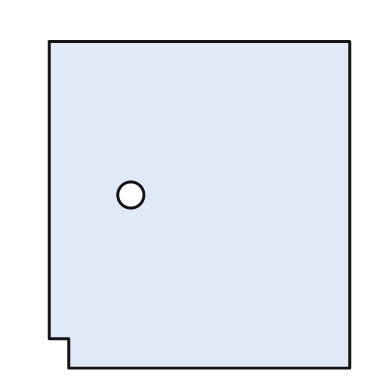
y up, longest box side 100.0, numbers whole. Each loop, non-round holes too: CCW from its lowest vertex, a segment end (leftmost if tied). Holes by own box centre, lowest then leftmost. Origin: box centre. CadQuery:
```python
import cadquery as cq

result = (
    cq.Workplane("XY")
    .moveTo(-40.0, -50.0)
    .lineTo(46.0, -50.0)
    .lineTo(46.0, 50.0)
    .lineTo(-46.0, 50.0)
    .lineTo(-46.0, -41.0)
    .lineTo(-40.0, -41.0)
    .close()
    .moveTo(-21.0, 3.0)
    .circle(4.0)
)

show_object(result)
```